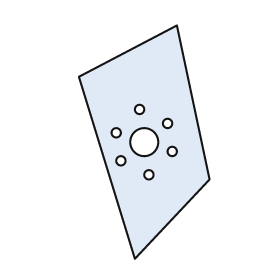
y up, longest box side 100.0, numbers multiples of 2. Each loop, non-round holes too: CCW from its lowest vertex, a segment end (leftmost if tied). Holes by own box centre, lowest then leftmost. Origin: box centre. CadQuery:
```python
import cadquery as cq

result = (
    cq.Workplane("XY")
    .moveTo(-4.0, -50.0)
    .lineTo(28.0, -16.0)
    .lineTo(14.0, 50.0)
    .lineTo(-28.0, 28.0)
    .close()
    .moveTo(2.0, -14.0)
    .circle(2.0)
    .moveTo(-10.0, -8.0)
    .circle(2.0)
    .moveTo(12.0, -4.0)
    .circle(2.0)
    .moveTo(0.0, 0.0)
    .circle(6.0)
    .moveTo(-12.0, 4.0)
    .circle(2.0)
    .moveTo(10.0, 8.0)
    .circle(2.0)
    .moveTo(-2.0, 14.0)
    .circle(2.0)
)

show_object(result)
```